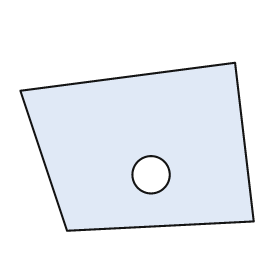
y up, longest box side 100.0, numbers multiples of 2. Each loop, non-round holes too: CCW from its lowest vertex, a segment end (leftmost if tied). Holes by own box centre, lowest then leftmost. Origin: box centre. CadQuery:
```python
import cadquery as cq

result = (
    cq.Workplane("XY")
    .moveTo(-30.0, -36.0)
    .lineTo(50.0, -32.0)
    .lineTo(42.0, 36.0)
    .lineTo(-50.0, 24.0)
    .close()
    .moveTo(6.0, -12.0)
    .circle(8.0)
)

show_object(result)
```